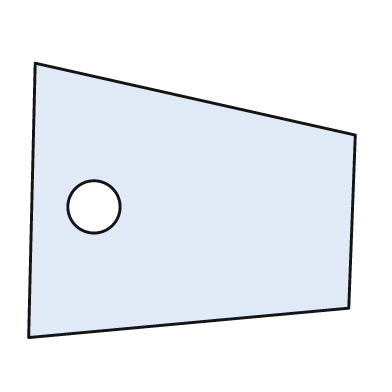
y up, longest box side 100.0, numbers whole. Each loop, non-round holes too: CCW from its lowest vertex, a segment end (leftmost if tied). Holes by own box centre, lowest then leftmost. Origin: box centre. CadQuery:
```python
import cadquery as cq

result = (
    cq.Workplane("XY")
    .moveTo(-50.0, -42.0)
    .lineTo(48.0, -33.0)
    .lineTo(50.0, 20.0)
    .lineTo(-48.0, 42.0)
    .close()
    .moveTo(-30.0, -2.0)
    .circle(8.0)
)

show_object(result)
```